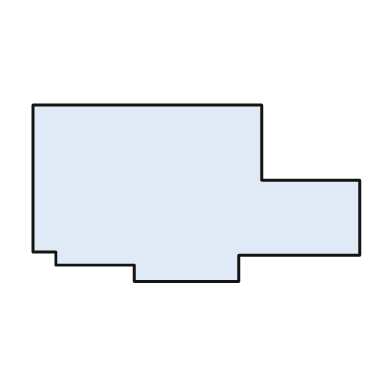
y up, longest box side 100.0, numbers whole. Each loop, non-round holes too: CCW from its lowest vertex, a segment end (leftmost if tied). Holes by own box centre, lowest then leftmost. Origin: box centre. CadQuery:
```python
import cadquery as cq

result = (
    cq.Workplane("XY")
    .moveTo(-19.0, -27.0)
    .lineTo(13.0, -27.0)
    .lineTo(13.0, -19.0)
    .lineTo(50.0, -19.0)
    .lineTo(50.0, 4.0)
    .lineTo(20.0, 4.0)
    .lineTo(20.0, 27.0)
    .lineTo(-50.0, 27.0)
    .lineTo(-50.0, -18.0)
    .lineTo(-43.0, -18.0)
    .lineTo(-43.0, -22.0)
    .lineTo(-19.0, -22.0)
    .close()
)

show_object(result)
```